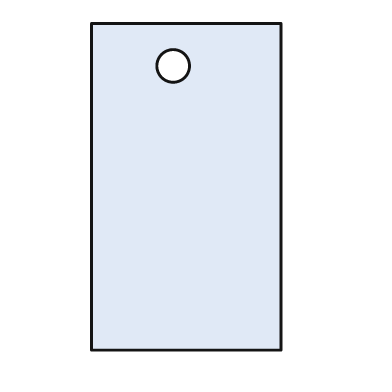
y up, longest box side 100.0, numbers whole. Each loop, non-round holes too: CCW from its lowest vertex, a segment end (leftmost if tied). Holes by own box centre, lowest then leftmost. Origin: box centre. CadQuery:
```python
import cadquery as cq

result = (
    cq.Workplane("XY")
    .moveTo(-29.0, -50.0)
    .lineTo(29.0, -50.0)
    .lineTo(29.0, 50.0)
    .lineTo(-29.0, 50.0)
    .close()
    .moveTo(-4.0, 37.0)
    .circle(5.0)
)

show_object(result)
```